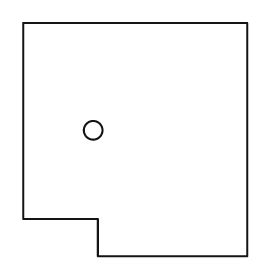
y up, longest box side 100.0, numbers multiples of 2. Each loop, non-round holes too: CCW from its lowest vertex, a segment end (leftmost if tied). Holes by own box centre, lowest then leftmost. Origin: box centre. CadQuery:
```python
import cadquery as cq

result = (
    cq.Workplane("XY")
    .moveTo(-16.0, -50.0)
    .lineTo(48.0, -50.0)
    .lineTo(48.0, 50.0)
    .lineTo(-48.0, 50.0)
    .lineTo(-48.0, -34.0)
    .lineTo(-16.0, -34.0)
    .close()
    .moveTo(-18.0, 4.0)
    .circle(4.0)
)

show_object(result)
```